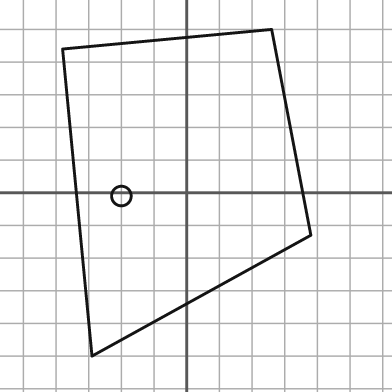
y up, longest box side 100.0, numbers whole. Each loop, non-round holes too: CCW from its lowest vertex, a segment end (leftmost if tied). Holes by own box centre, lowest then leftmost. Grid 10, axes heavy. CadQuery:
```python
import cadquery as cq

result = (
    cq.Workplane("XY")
    .moveTo(-29.0, -50.0)
    .lineTo(38.0, -13.0)
    .lineTo(26.0, 50.0)
    .lineTo(-38.0, 44.0)
    .close()
    .moveTo(-20.0, -1.0)
    .circle(3.0)
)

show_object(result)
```